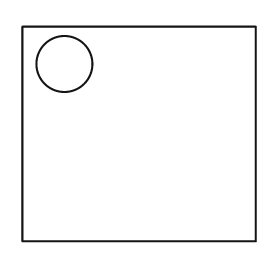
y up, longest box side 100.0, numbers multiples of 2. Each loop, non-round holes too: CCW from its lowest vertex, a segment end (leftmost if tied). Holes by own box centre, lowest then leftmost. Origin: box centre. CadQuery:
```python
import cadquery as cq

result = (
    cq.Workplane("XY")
    .moveTo(-50.0, -46.0)
    .lineTo(50.0, -46.0)
    .lineTo(50.0, 46.0)
    .lineTo(-50.0, 46.0)
    .close()
    .moveTo(-32.0, 30.0)
    .circle(12.0)
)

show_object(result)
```